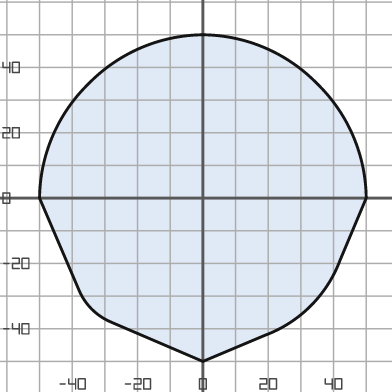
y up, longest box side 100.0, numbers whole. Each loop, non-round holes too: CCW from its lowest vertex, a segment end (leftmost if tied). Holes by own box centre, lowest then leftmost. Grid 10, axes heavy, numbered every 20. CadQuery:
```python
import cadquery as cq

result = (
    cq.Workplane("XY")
    .moveTo(0.0, -50.0)
    .lineTo(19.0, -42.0)
    .threePointArc((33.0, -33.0), (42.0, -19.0))
    .lineTo(50.0, 0.0)
    .threePointArc((46.0, 19.0), (35.0, 35.0))
    .threePointArc((19.0, 46.0), (0.0, 50.0))
    .threePointArc((-19.0, 46.0), (-35.0, 35.0))
    .threePointArc((-46.0, 19.0), (-50.0, 0.0))
    .lineTo(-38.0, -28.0)
    .threePointArc((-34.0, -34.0), (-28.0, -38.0))
    .close()
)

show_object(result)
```